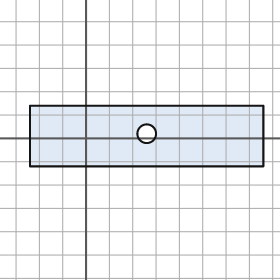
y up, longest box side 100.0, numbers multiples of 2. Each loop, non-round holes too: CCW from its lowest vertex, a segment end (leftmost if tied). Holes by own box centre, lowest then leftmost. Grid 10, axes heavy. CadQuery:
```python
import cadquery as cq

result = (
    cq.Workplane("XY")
    .moveTo(-24.0, -12.0)
    .lineTo(76.0, -12.0)
    .lineTo(76.0, 14.0)
    .lineTo(-24.0, 14.0)
    .close()
    .moveTo(26.0, 2.0)
    .circle(4.0)
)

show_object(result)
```